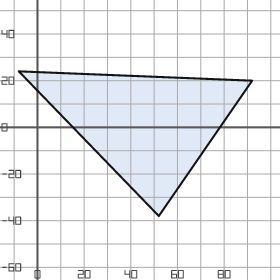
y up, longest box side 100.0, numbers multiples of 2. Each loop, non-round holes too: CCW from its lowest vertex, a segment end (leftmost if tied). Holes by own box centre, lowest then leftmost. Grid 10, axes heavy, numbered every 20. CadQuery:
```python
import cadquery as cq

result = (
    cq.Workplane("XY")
    .moveTo(52.0, -38.0)
    .lineTo(92.0, 20.0)
    .lineTo(-8.0, 24.0)
    .close()
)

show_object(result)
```